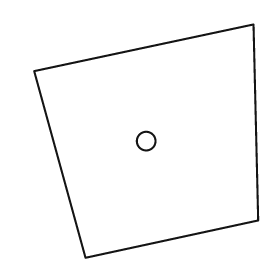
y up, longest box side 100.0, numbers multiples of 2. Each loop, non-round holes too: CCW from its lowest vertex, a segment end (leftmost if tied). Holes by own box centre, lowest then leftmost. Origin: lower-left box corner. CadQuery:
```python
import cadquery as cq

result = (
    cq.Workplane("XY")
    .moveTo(22.0, 0.0)
    .lineTo(96.0, 16.0)
    .lineTo(94.0, 100.0)
    .lineTo(0.0, 80.0)
    .close()
    .moveTo(48.0, 50.0)
    .circle(4.0)
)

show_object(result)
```